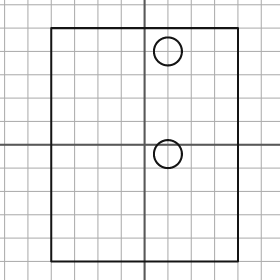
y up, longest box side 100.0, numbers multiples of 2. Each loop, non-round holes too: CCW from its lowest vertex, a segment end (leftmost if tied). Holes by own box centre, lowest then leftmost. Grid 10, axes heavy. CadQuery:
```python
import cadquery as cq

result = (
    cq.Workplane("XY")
    .moveTo(-40.0, -50.0)
    .lineTo(40.0, -50.0)
    .lineTo(40.0, 50.0)
    .lineTo(-40.0, 50.0)
    .close()
    .moveTo(10.0, -4.0)
    .circle(6.0)
    .moveTo(10.0, 40.0)
    .circle(6.0)
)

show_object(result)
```